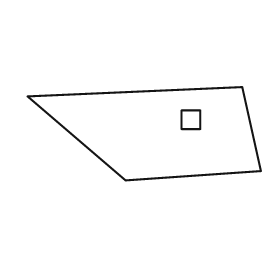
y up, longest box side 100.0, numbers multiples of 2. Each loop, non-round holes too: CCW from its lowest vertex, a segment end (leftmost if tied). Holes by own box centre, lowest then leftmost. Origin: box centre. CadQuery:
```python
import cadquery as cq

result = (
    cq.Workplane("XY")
    .moveTo(-8.0, -20.0)
    .lineTo(50.0, -16.0)
    .lineTo(42.0, 20.0)
    .lineTo(-50.0, 16.0)
    .close()
    .moveTo(16.0, 2.0)
    .lineTo(24.0, 2.0)
    .lineTo(24.0, 10.0)
    .lineTo(16.0, 10.0)
    .close()
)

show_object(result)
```